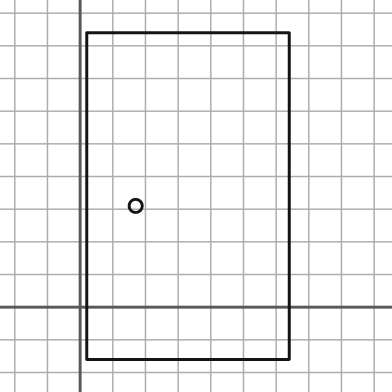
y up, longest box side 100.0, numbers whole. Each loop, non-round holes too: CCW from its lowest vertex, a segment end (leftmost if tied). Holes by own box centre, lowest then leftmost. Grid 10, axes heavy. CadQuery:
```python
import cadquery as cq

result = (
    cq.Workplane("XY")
    .moveTo(2.0, -16.0)
    .lineTo(64.0, -16.0)
    .lineTo(64.0, 84.0)
    .lineTo(2.0, 84.0)
    .close()
    .moveTo(17.0, 31.0)
    .circle(2.0)
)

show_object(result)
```